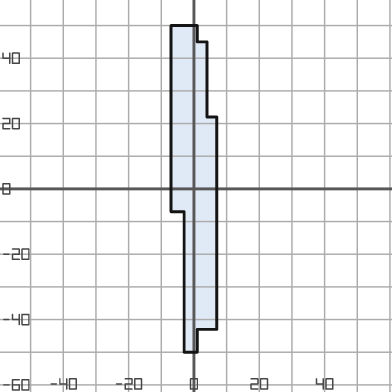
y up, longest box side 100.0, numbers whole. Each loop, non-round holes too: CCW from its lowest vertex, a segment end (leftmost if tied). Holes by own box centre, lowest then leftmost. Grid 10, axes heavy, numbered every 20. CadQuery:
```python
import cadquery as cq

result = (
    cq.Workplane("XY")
    .moveTo(-3.0, -50.0)
    .lineTo(1.0, -50.0)
    .lineTo(1.0, -43.0)
    .lineTo(7.0, -43.0)
    .lineTo(7.0, 22.0)
    .lineTo(4.0, 22.0)
    .lineTo(4.0, 45.0)
    .lineTo(1.0, 45.0)
    .lineTo(1.0, 50.0)
    .lineTo(-7.0, 50.0)
    .lineTo(-7.0, -7.0)
    .lineTo(-3.0, -7.0)
    .close()
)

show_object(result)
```